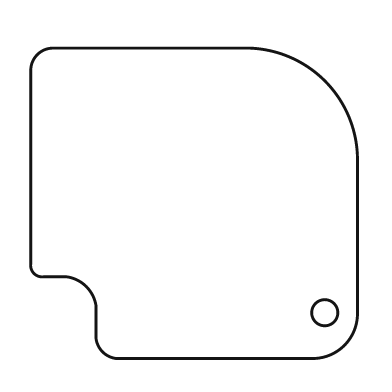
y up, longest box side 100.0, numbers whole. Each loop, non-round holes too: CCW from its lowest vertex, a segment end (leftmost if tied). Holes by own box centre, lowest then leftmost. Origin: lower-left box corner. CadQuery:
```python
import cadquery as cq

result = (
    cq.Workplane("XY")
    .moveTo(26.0, 0.0)
    .lineTo(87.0, 0.0)
    .threePointArc((96.0, 4.0), (100.0, 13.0))
    .lineTo(100.0, 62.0)
    .threePointArc((90.0, 85.0), (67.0, 95.0))
    .lineTo(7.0, 95.0)
    .threePointArc((2.0, 93.0), (0.0, 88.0))
    .lineTo(0.0, 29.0)
    .threePointArc((1.0, 26.0), (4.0, 25.0))
    .lineTo(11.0, 25.0)
    .threePointArc((17.0, 22.0), (20.0, 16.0))
    .lineTo(20.0, 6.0)
    .threePointArc((22.0, 2.0), (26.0, 0.0))
    .close()
    .moveTo(90.0, 14.0)
    .circle(4.0)
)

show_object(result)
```